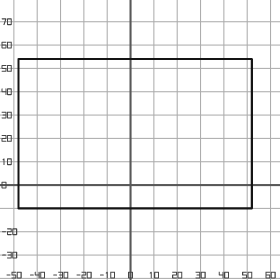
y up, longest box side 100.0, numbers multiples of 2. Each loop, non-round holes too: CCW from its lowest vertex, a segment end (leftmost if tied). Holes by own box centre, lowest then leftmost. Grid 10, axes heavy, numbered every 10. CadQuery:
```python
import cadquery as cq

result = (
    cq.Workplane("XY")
    .moveTo(-48.0, -10.0)
    .lineTo(52.0, -10.0)
    .lineTo(52.0, 54.0)
    .lineTo(-48.0, 54.0)
    .close()
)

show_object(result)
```